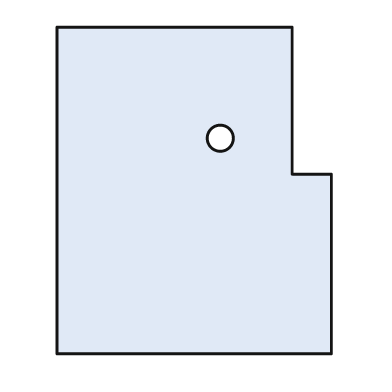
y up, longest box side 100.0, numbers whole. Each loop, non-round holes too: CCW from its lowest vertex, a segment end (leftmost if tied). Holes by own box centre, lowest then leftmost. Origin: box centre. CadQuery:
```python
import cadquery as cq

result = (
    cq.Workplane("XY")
    .moveTo(-42.0, -50.0)
    .lineTo(42.0, -50.0)
    .lineTo(42.0, 5.0)
    .lineTo(30.0, 5.0)
    .lineTo(30.0, 50.0)
    .lineTo(-42.0, 50.0)
    .close()
    .moveTo(8.0, 16.0)
    .circle(4.0)
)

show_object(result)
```